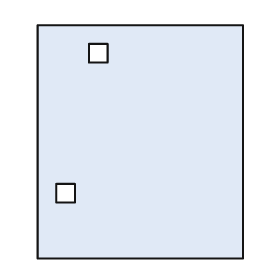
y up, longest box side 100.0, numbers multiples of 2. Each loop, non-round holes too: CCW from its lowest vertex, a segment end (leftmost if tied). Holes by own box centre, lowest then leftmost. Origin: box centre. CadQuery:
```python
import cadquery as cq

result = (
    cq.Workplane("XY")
    .moveTo(-44.0, -50.0)
    .lineTo(44.0, -50.0)
    .lineTo(44.0, 50.0)
    .lineTo(-44.0, 50.0)
    .close()
    .moveTo(-36.0, -26.0)
    .lineTo(-28.0, -26.0)
    .lineTo(-28.0, -18.0)
    .lineTo(-36.0, -18.0)
    .close()
    .moveTo(-22.0, 34.0)
    .lineTo(-14.0, 34.0)
    .lineTo(-14.0, 42.0)
    .lineTo(-22.0, 42.0)
    .close()
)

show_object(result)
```